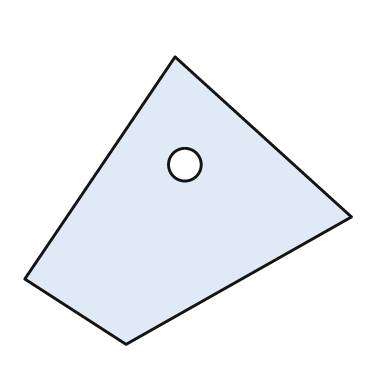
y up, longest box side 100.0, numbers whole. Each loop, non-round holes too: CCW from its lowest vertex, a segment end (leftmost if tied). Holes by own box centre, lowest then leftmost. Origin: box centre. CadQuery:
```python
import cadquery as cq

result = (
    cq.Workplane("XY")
    .moveTo(-19.0, -44.0)
    .lineTo(50.0, -5.0)
    .lineTo(-4.0, 44.0)
    .lineTo(-50.0, -24.0)
    .close()
    .moveTo(-1.0, 11.0)
    .circle(5.0)
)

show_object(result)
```